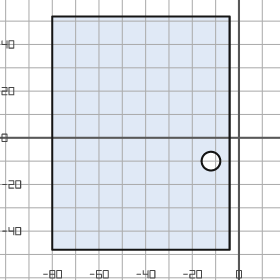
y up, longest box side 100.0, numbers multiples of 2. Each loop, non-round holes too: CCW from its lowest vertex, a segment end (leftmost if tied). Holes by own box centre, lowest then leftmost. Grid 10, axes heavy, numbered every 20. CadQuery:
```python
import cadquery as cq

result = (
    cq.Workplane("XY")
    .moveTo(-80.0, -48.0)
    .lineTo(-4.0, -48.0)
    .lineTo(-4.0, 52.0)
    .lineTo(-80.0, 52.0)
    .close()
    .moveTo(-12.0, -10.0)
    .circle(4.0)
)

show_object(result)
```